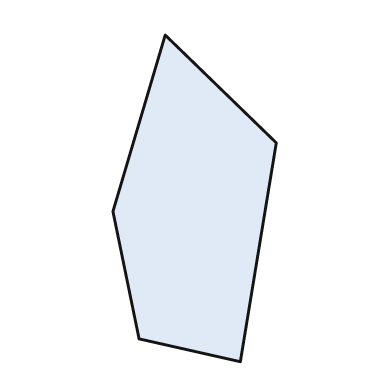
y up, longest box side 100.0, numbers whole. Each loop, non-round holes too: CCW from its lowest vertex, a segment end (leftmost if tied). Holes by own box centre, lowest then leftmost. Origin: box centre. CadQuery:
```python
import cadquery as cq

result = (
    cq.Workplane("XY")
    .moveTo(14.0, -50.0)
    .lineTo(25.0, 17.0)
    .lineTo(-9.0, 50.0)
    .lineTo(-25.0, -4.0)
    .lineTo(-17.0, -43.0)
    .close()
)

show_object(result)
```